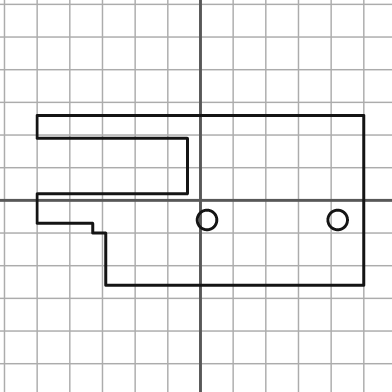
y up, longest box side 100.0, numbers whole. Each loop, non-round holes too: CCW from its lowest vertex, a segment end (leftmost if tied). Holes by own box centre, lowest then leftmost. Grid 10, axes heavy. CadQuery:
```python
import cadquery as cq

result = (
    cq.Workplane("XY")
    .moveTo(-29.0, -26.0)
    .lineTo(50.0, -26.0)
    .lineTo(50.0, 26.0)
    .lineTo(-50.0, 26.0)
    .lineTo(-50.0, 19.0)
    .lineTo(-4.0, 19.0)
    .lineTo(-4.0, 2.0)
    .lineTo(-50.0, 2.0)
    .lineTo(-50.0, -7.0)
    .lineTo(-33.0, -7.0)
    .lineTo(-33.0, -10.0)
    .lineTo(-29.0, -10.0)
    .close()
    .moveTo(2.0, -6.0)
    .circle(3.0)
    .moveTo(42.0, -6.0)
    .circle(3.0)
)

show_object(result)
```